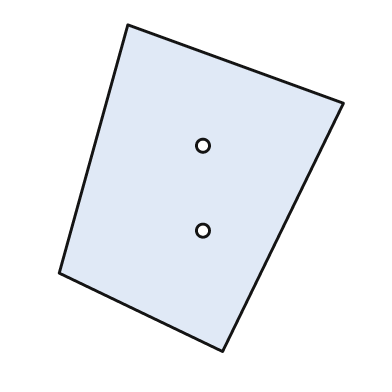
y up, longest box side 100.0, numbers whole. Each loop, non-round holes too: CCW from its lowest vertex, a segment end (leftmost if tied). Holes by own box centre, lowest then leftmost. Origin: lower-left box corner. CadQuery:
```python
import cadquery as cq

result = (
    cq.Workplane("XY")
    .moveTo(50.0, 0.0)
    .lineTo(87.0, 76.0)
    .lineTo(21.0, 100.0)
    .lineTo(0.0, 24.0)
    .close()
    .moveTo(44.0, 37.0)
    .circle(2.0)
    .moveTo(44.0, 63.0)
    .circle(2.0)
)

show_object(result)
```